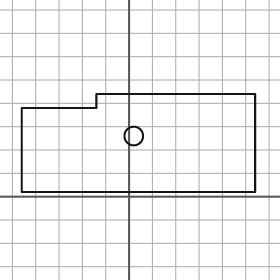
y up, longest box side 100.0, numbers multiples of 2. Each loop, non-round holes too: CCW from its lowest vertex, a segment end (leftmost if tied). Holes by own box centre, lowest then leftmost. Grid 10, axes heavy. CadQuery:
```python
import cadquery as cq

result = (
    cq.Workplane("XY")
    .moveTo(-46.0, 2.0)
    .lineTo(54.0, 2.0)
    .lineTo(54.0, 44.0)
    .lineTo(-14.0, 44.0)
    .lineTo(-14.0, 38.0)
    .lineTo(-46.0, 38.0)
    .close()
    .moveTo(2.0, 26.0)
    .circle(4.0)
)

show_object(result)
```